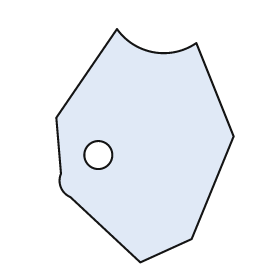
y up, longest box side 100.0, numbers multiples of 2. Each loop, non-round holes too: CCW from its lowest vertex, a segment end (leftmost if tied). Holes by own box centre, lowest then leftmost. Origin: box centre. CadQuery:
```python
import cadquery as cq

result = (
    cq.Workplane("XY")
    .moveTo(-2.0, -50.0)
    .lineTo(20.0, -40.0)
    .lineTo(38.0, 4.0)
    .lineTo(22.0, 44.0)
    .threePointArc((4.0, 40.0), (-12.0, 50.0))
    .lineTo(-38.0, 12.0)
    .lineTo(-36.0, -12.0)
    .threePointArc((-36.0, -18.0), (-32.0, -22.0))
    .close()
    .moveTo(-20.0, -4.0)
    .circle(6.0)
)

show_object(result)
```